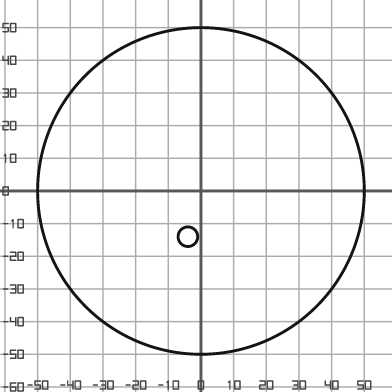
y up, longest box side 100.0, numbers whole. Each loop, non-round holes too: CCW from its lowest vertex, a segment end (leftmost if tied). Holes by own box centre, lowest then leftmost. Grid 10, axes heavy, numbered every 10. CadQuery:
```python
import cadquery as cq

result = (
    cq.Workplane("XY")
    .moveTo(0.0, 0.0)
    .circle(50.0)
    .moveTo(-4.0, -14.0)
    .circle(3.0)
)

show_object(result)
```